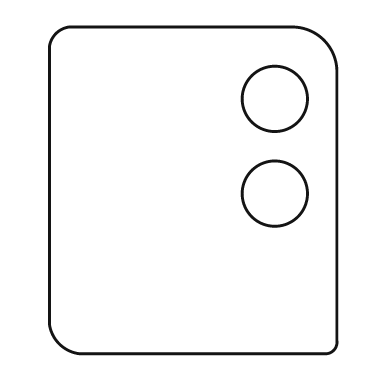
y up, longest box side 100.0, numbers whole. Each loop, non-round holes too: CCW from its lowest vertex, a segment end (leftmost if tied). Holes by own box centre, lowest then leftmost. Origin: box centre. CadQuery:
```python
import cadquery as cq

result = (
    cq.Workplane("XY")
    .moveTo(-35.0, -50.0)
    .lineTo(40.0, -50.0)
    .threePointArc((43.0, -49.0), (44.0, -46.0))
    .lineTo(44.0, 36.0)
    .threePointArc((40.0, 46.0), (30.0, 50.0))
    .lineTo(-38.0, 50.0)
    .threePointArc((-42.0, 48.0), (-44.0, 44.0))
    .lineTo(-44.0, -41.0)
    .threePointArc((-41.0, -47.0), (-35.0, -50.0))
    .close()
    .moveTo(25.0, -1.0)
    .circle(10.0)
    .moveTo(25.0, 28.0)
    .circle(10.0)
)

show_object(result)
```